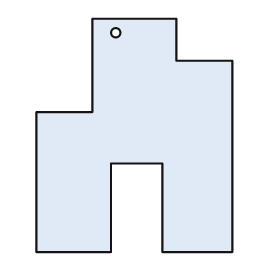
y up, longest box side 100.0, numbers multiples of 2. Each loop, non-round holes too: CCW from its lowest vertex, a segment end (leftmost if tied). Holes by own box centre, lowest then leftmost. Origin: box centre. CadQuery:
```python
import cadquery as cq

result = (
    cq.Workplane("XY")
    .moveTo(-42.0, -50.0)
    .lineTo(-10.0, -50.0)
    .lineTo(-10.0, -12.0)
    .lineTo(12.0, -12.0)
    .lineTo(12.0, -50.0)
    .lineTo(42.0, -50.0)
    .lineTo(42.0, 32.0)
    .lineTo(18.0, 32.0)
    .lineTo(18.0, 50.0)
    .lineTo(-18.0, 50.0)
    .lineTo(-18.0, 10.0)
    .lineTo(-42.0, 10.0)
    .close()
    .moveTo(-8.0, 44.0)
    .circle(2.0)
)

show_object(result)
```